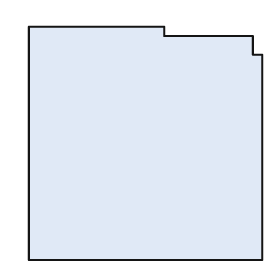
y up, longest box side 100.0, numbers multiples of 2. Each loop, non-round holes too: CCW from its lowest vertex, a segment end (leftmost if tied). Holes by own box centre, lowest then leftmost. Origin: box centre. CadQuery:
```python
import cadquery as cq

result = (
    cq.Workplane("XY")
    .moveTo(-50.0, -50.0)
    .lineTo(50.0, -50.0)
    .lineTo(50.0, 38.0)
    .lineTo(46.0, 38.0)
    .lineTo(46.0, 46.0)
    .lineTo(8.0, 46.0)
    .lineTo(8.0, 50.0)
    .lineTo(-50.0, 50.0)
    .close()
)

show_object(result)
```